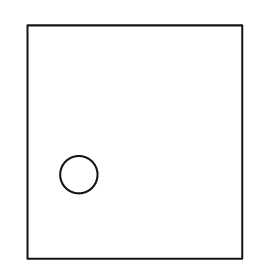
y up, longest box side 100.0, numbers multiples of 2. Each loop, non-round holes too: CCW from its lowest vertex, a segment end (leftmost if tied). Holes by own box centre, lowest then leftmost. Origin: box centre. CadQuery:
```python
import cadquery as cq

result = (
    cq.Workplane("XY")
    .moveTo(-46.0, -50.0)
    .lineTo(46.0, -50.0)
    .lineTo(46.0, 50.0)
    .lineTo(-46.0, 50.0)
    .close()
    .moveTo(-24.0, -14.0)
    .circle(8.0)
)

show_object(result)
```